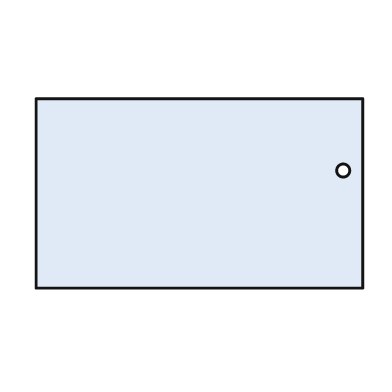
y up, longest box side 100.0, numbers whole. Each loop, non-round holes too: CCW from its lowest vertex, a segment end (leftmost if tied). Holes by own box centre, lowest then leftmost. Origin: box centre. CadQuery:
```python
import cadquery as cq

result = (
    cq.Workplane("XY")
    .moveTo(-50.0, -29.0)
    .lineTo(50.0, -29.0)
    .lineTo(50.0, 29.0)
    .lineTo(-50.0, 29.0)
    .close()
    .moveTo(44.0, 7.0)
    .circle(2.0)
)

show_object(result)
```